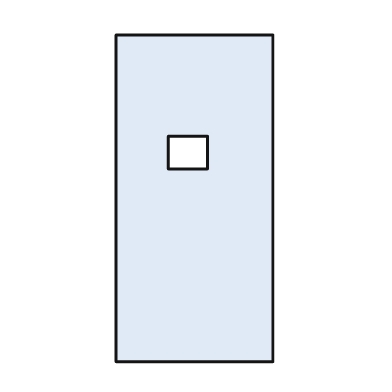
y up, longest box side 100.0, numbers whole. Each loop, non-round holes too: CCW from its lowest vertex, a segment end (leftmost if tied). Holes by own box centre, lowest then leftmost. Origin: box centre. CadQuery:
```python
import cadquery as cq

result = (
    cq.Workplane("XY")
    .moveTo(-24.0, -50.0)
    .lineTo(24.0, -50.0)
    .lineTo(24.0, 50.0)
    .lineTo(-24.0, 50.0)
    .close()
    .moveTo(-8.0, 9.0)
    .lineTo(4.0, 9.0)
    .lineTo(4.0, 19.0)
    .lineTo(-8.0, 19.0)
    .close()
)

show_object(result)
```